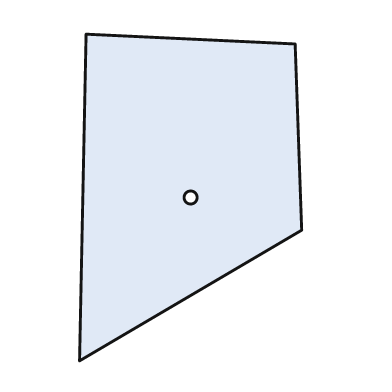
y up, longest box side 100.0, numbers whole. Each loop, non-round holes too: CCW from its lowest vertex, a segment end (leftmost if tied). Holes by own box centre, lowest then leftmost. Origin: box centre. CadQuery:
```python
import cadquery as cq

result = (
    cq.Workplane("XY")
    .moveTo(-34.0, -50.0)
    .lineTo(34.0, -10.0)
    .lineTo(32.0, 47.0)
    .lineTo(-32.0, 50.0)
    .close()
    .moveTo(0.0, 0.0)
    .circle(2.0)
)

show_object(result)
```